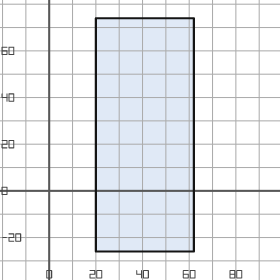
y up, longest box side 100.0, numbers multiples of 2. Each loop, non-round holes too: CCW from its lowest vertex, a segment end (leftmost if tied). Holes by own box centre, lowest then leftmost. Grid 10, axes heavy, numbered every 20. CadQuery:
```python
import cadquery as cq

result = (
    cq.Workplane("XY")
    .moveTo(20.0, -26.0)
    .lineTo(62.0, -26.0)
    .lineTo(62.0, 74.0)
    .lineTo(20.0, 74.0)
    .close()
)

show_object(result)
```